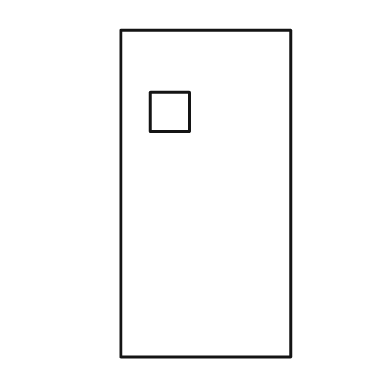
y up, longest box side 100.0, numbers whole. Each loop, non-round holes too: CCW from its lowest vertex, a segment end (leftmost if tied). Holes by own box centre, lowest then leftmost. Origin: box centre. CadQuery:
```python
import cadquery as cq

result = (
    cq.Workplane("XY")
    .moveTo(-26.0, -50.0)
    .lineTo(26.0, -50.0)
    .lineTo(26.0, 50.0)
    .lineTo(-26.0, 50.0)
    .close()
    .moveTo(-17.0, 19.0)
    .lineTo(-5.0, 19.0)
    .lineTo(-5.0, 31.0)
    .lineTo(-17.0, 31.0)
    .close()
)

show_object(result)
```